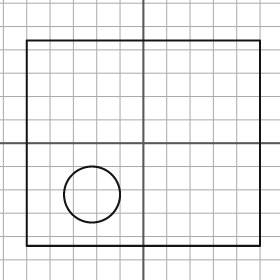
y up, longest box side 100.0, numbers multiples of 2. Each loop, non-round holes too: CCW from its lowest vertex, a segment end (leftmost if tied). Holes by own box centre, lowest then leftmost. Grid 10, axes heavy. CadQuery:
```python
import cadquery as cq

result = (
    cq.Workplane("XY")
    .moveTo(-50.0, -44.0)
    .lineTo(50.0, -44.0)
    .lineTo(50.0, 44.0)
    .lineTo(-50.0, 44.0)
    .close()
    .moveTo(-22.0, -22.0)
    .circle(12.0)
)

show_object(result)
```